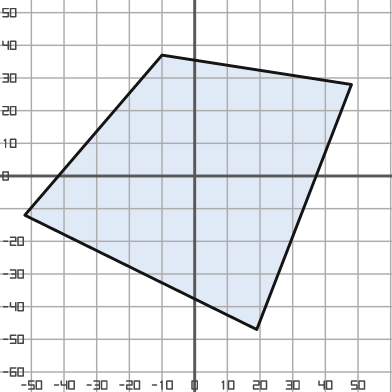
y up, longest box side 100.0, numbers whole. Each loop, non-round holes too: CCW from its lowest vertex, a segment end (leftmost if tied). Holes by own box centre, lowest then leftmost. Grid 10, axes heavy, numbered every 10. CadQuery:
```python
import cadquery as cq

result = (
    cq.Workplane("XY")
    .moveTo(19.0, -47.0)
    .lineTo(48.0, 28.0)
    .lineTo(-10.0, 37.0)
    .lineTo(-52.0, -12.0)
    .close()
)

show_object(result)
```